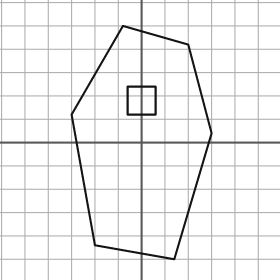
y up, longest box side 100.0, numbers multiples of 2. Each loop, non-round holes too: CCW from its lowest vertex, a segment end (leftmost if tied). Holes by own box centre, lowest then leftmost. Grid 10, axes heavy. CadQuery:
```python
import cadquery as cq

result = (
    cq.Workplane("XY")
    .moveTo(14.0, -50.0)
    .lineTo(30.0, 4.0)
    .lineTo(20.0, 42.0)
    .lineTo(-8.0, 50.0)
    .lineTo(-30.0, 12.0)
    .lineTo(-20.0, -44.0)
    .close()
    .moveTo(-6.0, 12.0)
    .lineTo(6.0, 12.0)
    .lineTo(6.0, 24.0)
    .lineTo(-6.0, 24.0)
    .close()
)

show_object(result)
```